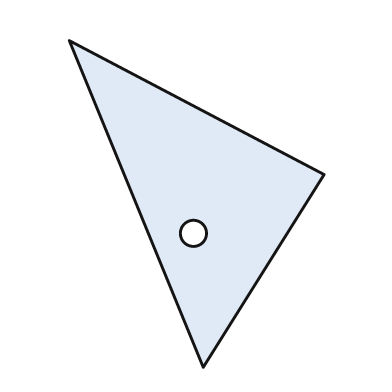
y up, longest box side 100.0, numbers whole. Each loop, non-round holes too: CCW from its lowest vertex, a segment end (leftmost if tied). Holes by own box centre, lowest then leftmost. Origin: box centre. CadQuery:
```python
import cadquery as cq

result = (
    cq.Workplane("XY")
    .moveTo(2.0, -50.0)
    .lineTo(39.0, 9.0)
    .lineTo(-39.0, 50.0)
    .close()
    .moveTo(-1.0, -9.0)
    .circle(4.0)
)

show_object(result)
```